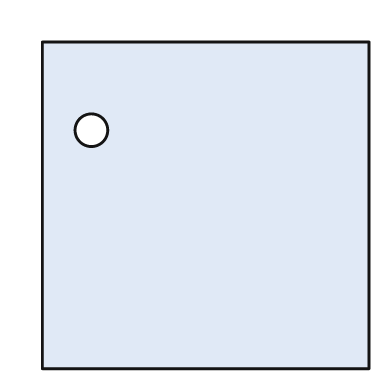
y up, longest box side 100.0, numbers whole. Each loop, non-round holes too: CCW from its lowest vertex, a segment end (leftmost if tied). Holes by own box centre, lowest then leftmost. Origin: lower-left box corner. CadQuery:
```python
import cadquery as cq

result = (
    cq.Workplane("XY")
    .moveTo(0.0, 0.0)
    .lineTo(100.0, 0.0)
    .lineTo(100.0, 100.0)
    .lineTo(0.0, 100.0)
    .close()
    .moveTo(15.0, 73.0)
    .circle(5.0)
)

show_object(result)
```